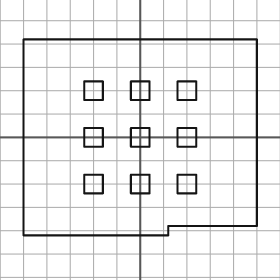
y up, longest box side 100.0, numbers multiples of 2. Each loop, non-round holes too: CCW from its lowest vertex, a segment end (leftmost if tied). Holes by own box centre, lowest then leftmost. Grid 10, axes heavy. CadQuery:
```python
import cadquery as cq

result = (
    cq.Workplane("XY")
    .moveTo(-50.0, -42.0)
    .lineTo(12.0, -42.0)
    .lineTo(12.0, -38.0)
    .lineTo(50.0, -38.0)
    .lineTo(50.0, 42.0)
    .lineTo(-50.0, 42.0)
    .close()
    .moveTo(-24.0, -24.0)
    .lineTo(-16.0, -24.0)
    .lineTo(-16.0, -16.0)
    .lineTo(-24.0, -16.0)
    .close()
    .moveTo(-4.0, -24.0)
    .lineTo(4.0, -24.0)
    .lineTo(4.0, -16.0)
    .lineTo(-4.0, -16.0)
    .close()
    .moveTo(16.0, -24.0)
    .lineTo(24.0, -24.0)
    .lineTo(24.0, -16.0)
    .lineTo(16.0, -16.0)
    .close()
    .moveTo(-24.0, -4.0)
    .lineTo(-16.0, -4.0)
    .lineTo(-16.0, 4.0)
    .lineTo(-24.0, 4.0)
    .close()
    .moveTo(-4.0, -4.0)
    .lineTo(4.0, -4.0)
    .lineTo(4.0, 4.0)
    .lineTo(-4.0, 4.0)
    .close()
    .moveTo(16.0, -4.0)
    .lineTo(24.0, -4.0)
    .lineTo(24.0, 4.0)
    .lineTo(16.0, 4.0)
    .close()
    .moveTo(-24.0, 16.0)
    .lineTo(-16.0, 16.0)
    .lineTo(-16.0, 24.0)
    .lineTo(-24.0, 24.0)
    .close()
    .moveTo(-4.0, 16.0)
    .lineTo(4.0, 16.0)
    .lineTo(4.0, 24.0)
    .lineTo(-4.0, 24.0)
    .close()
    .moveTo(16.0, 16.0)
    .lineTo(24.0, 16.0)
    .lineTo(24.0, 24.0)
    .lineTo(16.0, 24.0)
    .close()
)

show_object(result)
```